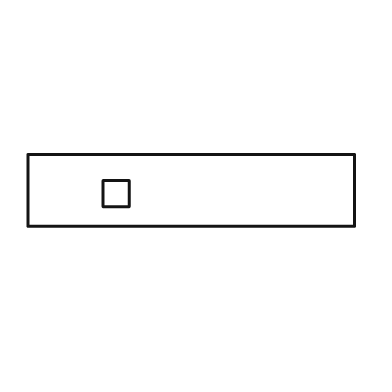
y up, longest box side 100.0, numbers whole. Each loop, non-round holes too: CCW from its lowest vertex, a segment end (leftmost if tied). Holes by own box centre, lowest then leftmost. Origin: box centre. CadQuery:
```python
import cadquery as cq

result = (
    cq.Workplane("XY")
    .moveTo(-50.0, -11.0)
    .lineTo(50.0, -11.0)
    .lineTo(50.0, 11.0)
    .lineTo(-50.0, 11.0)
    .close()
    .moveTo(-27.0, -5.0)
    .lineTo(-19.0, -5.0)
    .lineTo(-19.0, 3.0)
    .lineTo(-27.0, 3.0)
    .close()
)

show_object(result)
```